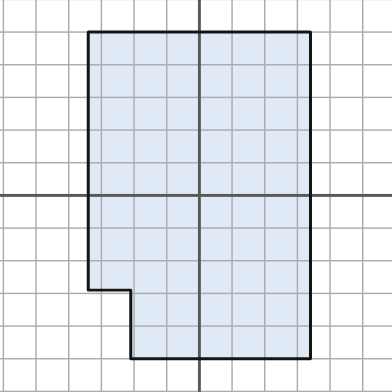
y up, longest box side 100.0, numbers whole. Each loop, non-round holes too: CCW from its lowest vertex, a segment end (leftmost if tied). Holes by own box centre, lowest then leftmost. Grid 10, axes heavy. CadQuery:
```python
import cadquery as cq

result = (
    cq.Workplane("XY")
    .moveTo(-21.0, -50.0)
    .lineTo(34.0, -50.0)
    .lineTo(34.0, 50.0)
    .lineTo(-34.0, 50.0)
    .lineTo(-34.0, -29.0)
    .lineTo(-21.0, -29.0)
    .close()
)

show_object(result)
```